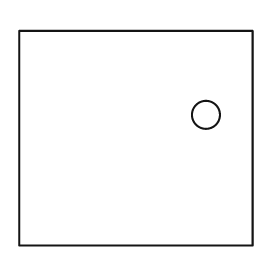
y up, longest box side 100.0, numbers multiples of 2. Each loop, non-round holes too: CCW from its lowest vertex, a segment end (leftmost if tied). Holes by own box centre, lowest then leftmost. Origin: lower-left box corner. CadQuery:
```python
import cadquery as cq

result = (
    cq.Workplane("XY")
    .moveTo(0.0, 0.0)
    .lineTo(100.0, 0.0)
    .lineTo(100.0, 92.0)
    .lineTo(0.0, 92.0)
    .close()
    .moveTo(80.0, 56.0)
    .circle(6.0)
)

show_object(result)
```